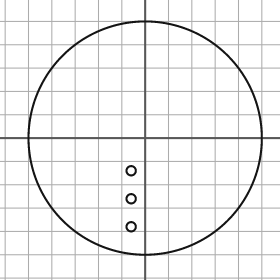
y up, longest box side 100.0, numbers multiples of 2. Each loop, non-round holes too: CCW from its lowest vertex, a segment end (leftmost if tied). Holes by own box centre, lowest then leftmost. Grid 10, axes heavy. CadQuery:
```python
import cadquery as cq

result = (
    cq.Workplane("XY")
    .moveTo(0.0, 0.0)
    .circle(50.0)
    .moveTo(-6.0, -38.0)
    .circle(2.0)
    .moveTo(-6.0, -26.0)
    .circle(2.0)
    .moveTo(-6.0, -14.0)
    .circle(2.0)
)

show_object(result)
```